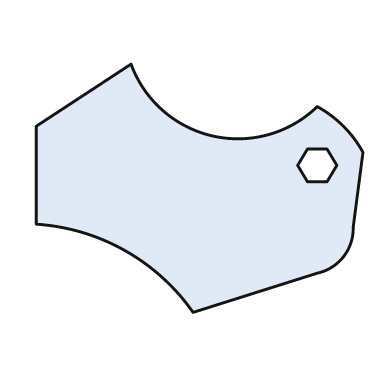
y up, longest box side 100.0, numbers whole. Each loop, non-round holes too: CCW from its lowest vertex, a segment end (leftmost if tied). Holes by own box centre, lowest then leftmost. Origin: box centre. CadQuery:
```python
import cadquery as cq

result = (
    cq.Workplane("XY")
    .moveTo(-2.0, -38.0)
    .lineTo(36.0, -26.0)
    .threePointArc((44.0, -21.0), (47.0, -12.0))
    .lineTo(50.0, 11.0)
    .threePointArc((44.0, 19.0), (36.0, 25.0))
    .threePointArc((4.0, 16.0), (-21.0, 38.0))
    .lineTo(-50.0, 19.0)
    .lineTo(-50.0, -11.0)
    .threePointArc((-23.0, -19.0), (-2.0, -38.0))
    .close()
    .moveTo(33.0, 2.0)
    .lineTo(39.0, 2.0)
    .lineTo(42.0, 7.0)
    .lineTo(39.0, 12.0)
    .lineTo(33.0, 12.0)
    .lineTo(30.0, 7.0)
    .close()
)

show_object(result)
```